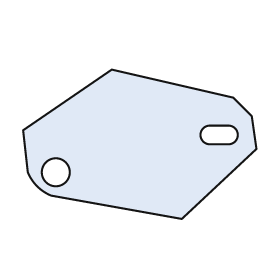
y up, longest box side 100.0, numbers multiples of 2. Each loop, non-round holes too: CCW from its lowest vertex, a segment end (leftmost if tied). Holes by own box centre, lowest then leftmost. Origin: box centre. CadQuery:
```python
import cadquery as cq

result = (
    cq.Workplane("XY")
    .moveTo(18.0, -32.0)
    .lineTo(50.0, -2.0)
    .lineTo(48.0, 12.0)
    .lineTo(40.0, 20.0)
    .lineTo(-12.0, 32.0)
    .lineTo(-50.0, 6.0)
    .lineTo(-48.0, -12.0)
    .threePointArc((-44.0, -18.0), (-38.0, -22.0))
    .close()
    .moveTo(-36.0, -12.0)
    .circle(6.0)
    .moveTo(30.0, 0.0)
    .lineTo(38.0, 0.0)
    .threePointArc((42.0, 4.0), (38.0, 8.0))
    .lineTo(30.0, 8.0)
    .threePointArc((26.0, 4.0), (30.0, 0.0))
    .close()
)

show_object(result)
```